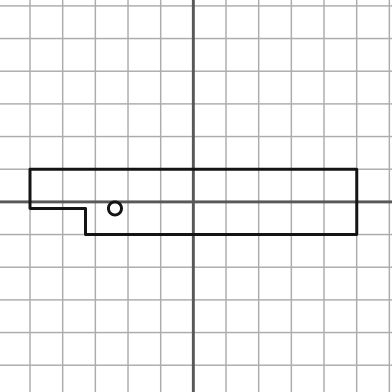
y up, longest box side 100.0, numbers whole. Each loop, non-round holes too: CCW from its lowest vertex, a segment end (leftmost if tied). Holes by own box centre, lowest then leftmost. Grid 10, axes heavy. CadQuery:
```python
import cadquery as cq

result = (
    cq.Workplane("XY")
    .moveTo(-33.0, -10.0)
    .lineTo(50.0, -10.0)
    .lineTo(50.0, 10.0)
    .lineTo(-50.0, 10.0)
    .lineTo(-50.0, -2.0)
    .lineTo(-33.0, -2.0)
    .close()
    .moveTo(-24.0, -2.0)
    .circle(2.0)
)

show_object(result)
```